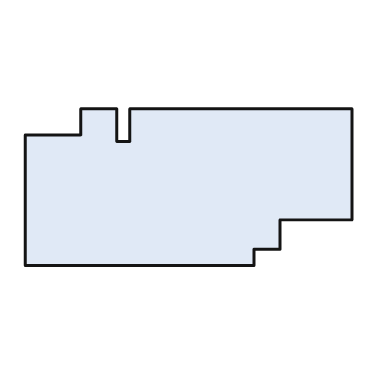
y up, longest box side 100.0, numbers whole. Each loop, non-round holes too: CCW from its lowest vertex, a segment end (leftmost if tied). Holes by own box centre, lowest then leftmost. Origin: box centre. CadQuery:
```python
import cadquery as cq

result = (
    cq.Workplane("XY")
    .moveTo(-50.0, -24.0)
    .lineTo(20.0, -24.0)
    .lineTo(20.0, -19.0)
    .lineTo(28.0, -19.0)
    .lineTo(28.0, -10.0)
    .lineTo(50.0, -10.0)
    .lineTo(50.0, 24.0)
    .lineTo(-18.0, 24.0)
    .lineTo(-18.0, 14.0)
    .lineTo(-22.0, 14.0)
    .lineTo(-22.0, 24.0)
    .lineTo(-33.0, 24.0)
    .lineTo(-33.0, 16.0)
    .lineTo(-50.0, 16.0)
    .close()
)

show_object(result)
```